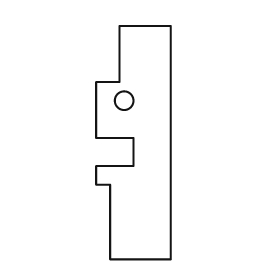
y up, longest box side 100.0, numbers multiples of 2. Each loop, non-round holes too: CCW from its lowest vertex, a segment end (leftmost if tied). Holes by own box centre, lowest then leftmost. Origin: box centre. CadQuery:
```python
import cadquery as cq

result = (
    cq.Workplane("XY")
    .moveTo(-10.0, -50.0)
    .lineTo(16.0, -50.0)
    .lineTo(16.0, 50.0)
    .lineTo(-6.0, 50.0)
    .lineTo(-6.0, 26.0)
    .lineTo(-16.0, 26.0)
    .lineTo(-16.0, 2.0)
    .lineTo(0.0, 2.0)
    .lineTo(0.0, -10.0)
    .lineTo(-16.0, -10.0)
    .lineTo(-16.0, -18.0)
    .lineTo(-10.0, -18.0)
    .close()
    .moveTo(-4.0, 18.0)
    .circle(4.0)
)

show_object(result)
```